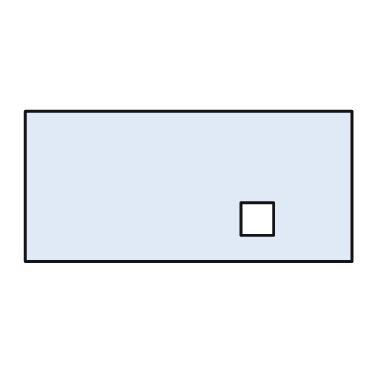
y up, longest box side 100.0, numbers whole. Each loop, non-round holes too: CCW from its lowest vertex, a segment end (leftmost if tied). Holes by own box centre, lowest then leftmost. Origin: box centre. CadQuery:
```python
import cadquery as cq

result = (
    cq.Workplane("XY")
    .moveTo(-50.0, -23.0)
    .lineTo(50.0, -23.0)
    .lineTo(50.0, 23.0)
    .lineTo(-50.0, 23.0)
    .close()
    .moveTo(16.0, -15.0)
    .lineTo(26.0, -15.0)
    .lineTo(26.0, -5.0)
    .lineTo(16.0, -5.0)
    .close()
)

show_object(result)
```